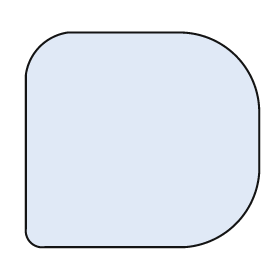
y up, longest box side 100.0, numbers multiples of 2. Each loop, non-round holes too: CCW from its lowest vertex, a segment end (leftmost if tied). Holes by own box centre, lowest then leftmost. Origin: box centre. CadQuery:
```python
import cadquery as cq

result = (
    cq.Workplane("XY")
    .moveTo(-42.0, -46.0)
    .lineTo(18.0, -46.0)
    .threePointArc((40.0, -36.0), (50.0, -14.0))
    .lineTo(50.0, 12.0)
    .threePointArc((40.0, 36.0), (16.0, 46.0))
    .lineTo(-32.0, 46.0)
    .threePointArc((-44.0, 40.0), (-50.0, 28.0))
    .lineTo(-50.0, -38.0)
    .threePointArc((-48.0, -44.0), (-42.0, -46.0))
    .close()
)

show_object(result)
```